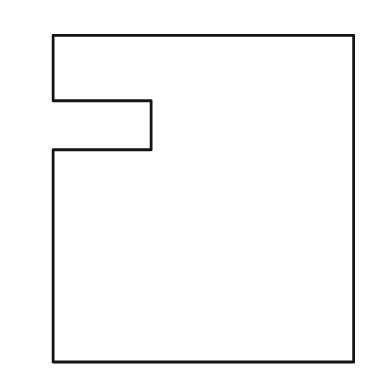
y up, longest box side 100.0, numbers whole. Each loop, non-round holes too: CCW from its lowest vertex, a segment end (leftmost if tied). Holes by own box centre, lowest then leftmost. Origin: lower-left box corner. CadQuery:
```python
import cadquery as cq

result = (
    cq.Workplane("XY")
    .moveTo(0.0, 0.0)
    .lineTo(92.0, 0.0)
    .lineTo(92.0, 100.0)
    .lineTo(0.0, 100.0)
    .lineTo(0.0, 80.0)
    .lineTo(30.0, 80.0)
    .lineTo(30.0, 65.0)
    .lineTo(0.0, 65.0)
    .close()
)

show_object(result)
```